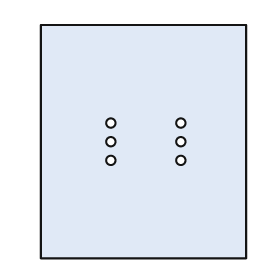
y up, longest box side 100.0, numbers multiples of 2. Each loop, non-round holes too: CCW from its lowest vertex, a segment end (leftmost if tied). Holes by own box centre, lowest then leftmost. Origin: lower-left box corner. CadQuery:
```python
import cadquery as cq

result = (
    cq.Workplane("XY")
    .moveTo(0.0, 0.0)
    .lineTo(88.0, 0.0)
    .lineTo(88.0, 100.0)
    .lineTo(0.0, 100.0)
    .close()
    .moveTo(30.0, 42.0)
    .circle(2.0)
    .moveTo(60.0, 42.0)
    .circle(2.0)
    .moveTo(30.0, 50.0)
    .circle(2.0)
    .moveTo(60.0, 50.0)
    .circle(2.0)
    .moveTo(30.0, 58.0)
    .circle(2.0)
    .moveTo(60.0, 58.0)
    .circle(2.0)
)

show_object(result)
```